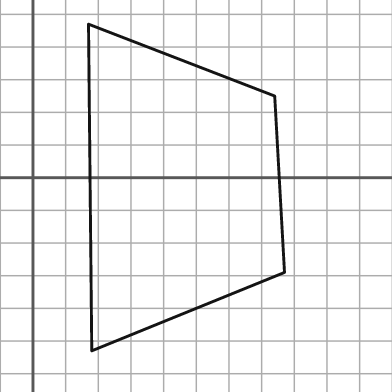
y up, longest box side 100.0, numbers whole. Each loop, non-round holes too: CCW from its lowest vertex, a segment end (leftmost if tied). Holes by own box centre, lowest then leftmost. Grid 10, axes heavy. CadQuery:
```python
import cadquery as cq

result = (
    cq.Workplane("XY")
    .moveTo(18.0, -53.0)
    .lineTo(77.0, -29.0)
    .lineTo(74.0, 25.0)
    .lineTo(17.0, 47.0)
    .close()
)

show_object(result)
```